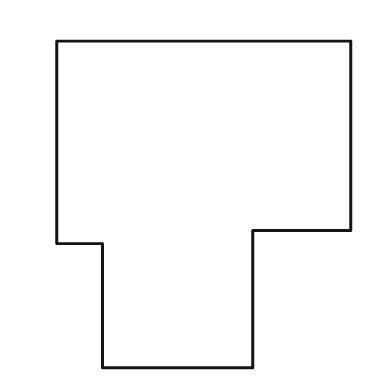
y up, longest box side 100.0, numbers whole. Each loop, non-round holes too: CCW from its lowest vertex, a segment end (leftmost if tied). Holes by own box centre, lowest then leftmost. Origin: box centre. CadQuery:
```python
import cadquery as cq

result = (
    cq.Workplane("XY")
    .moveTo(-31.0, -50.0)
    .lineTo(15.0, -50.0)
    .lineTo(15.0, -8.0)
    .lineTo(45.0, -8.0)
    .lineTo(45.0, 50.0)
    .lineTo(-45.0, 50.0)
    .lineTo(-45.0, -12.0)
    .lineTo(-31.0, -12.0)
    .close()
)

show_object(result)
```